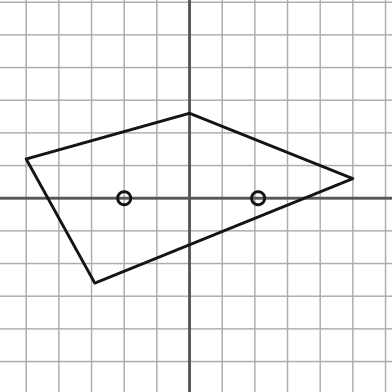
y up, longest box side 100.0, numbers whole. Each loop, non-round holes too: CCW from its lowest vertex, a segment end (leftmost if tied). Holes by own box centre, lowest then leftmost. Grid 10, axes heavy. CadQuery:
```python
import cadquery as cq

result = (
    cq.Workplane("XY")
    .moveTo(-29.0, -26.0)
    .lineTo(50.0, 6.0)
    .lineTo(0.0, 26.0)
    .lineTo(-50.0, 12.0)
    .close()
    .moveTo(-20.0, 0.0)
    .circle(2.0)
    .moveTo(21.0, 0.0)
    .circle(2.0)
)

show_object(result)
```